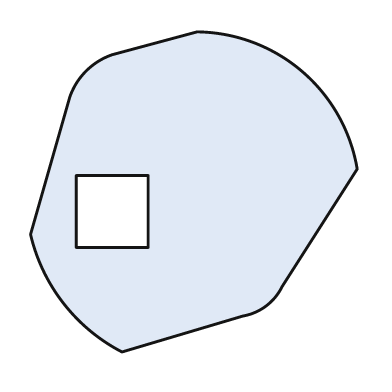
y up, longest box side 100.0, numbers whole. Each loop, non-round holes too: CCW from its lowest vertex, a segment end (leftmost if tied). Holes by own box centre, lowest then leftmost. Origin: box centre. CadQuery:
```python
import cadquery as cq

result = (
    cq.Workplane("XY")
    .moveTo(-22.0, -49.0)
    .lineTo(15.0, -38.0)
    .threePointArc((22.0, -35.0), (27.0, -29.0))
    .lineTo(50.0, 7.0)
    .threePointArc((33.0, 37.0), (1.0, 49.0))
    .lineTo(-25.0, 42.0)
    .threePointArc((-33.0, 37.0), (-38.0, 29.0))
    .lineTo(-50.0, -13.0)
    .threePointArc((-40.0, -34.0), (-22.0, -49.0))
    .close()
    .moveTo(-36.0, -17.0)
    .lineTo(-14.0, -17.0)
    .lineTo(-14.0, 5.0)
    .lineTo(-36.0, 5.0)
    .close()
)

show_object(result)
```